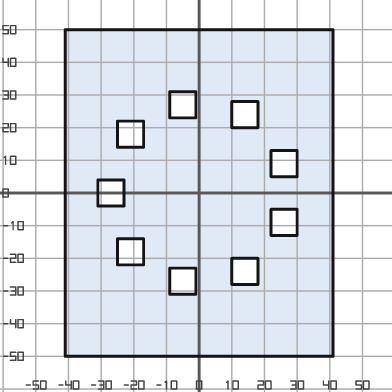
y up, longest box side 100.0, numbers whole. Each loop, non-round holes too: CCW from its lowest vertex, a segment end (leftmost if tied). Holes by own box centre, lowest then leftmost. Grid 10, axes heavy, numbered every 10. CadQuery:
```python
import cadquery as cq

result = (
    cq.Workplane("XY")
    .moveTo(-41.0, -50.0)
    .lineTo(41.0, -50.0)
    .lineTo(41.0, 50.0)
    .lineTo(-41.0, 50.0)
    .close()
    .moveTo(-9.0, -31.0)
    .lineTo(-1.0, -31.0)
    .lineTo(-1.0, -23.0)
    .lineTo(-9.0, -23.0)
    .close()
    .moveTo(10.0, -28.0)
    .lineTo(18.0, -28.0)
    .lineTo(18.0, -20.0)
    .lineTo(10.0, -20.0)
    .close()
    .moveTo(-25.0, -22.0)
    .lineTo(-17.0, -22.0)
    .lineTo(-17.0, -14.0)
    .lineTo(-25.0, -14.0)
    .close()
    .moveTo(22.0, -13.0)
    .lineTo(30.0, -13.0)
    .lineTo(30.0, -5.0)
    .lineTo(22.0, -5.0)
    .close()
    .moveTo(-31.0, -4.0)
    .lineTo(-23.0, -4.0)
    .lineTo(-23.0, 4.0)
    .lineTo(-31.0, 4.0)
    .close()
    .moveTo(22.0, 5.0)
    .lineTo(30.0, 5.0)
    .lineTo(30.0, 13.0)
    .lineTo(22.0, 13.0)
    .close()
    .moveTo(-25.0, 14.0)
    .lineTo(-17.0, 14.0)
    .lineTo(-17.0, 22.0)
    .lineTo(-25.0, 22.0)
    .close()
    .moveTo(10.0, 20.0)
    .lineTo(18.0, 20.0)
    .lineTo(18.0, 28.0)
    .lineTo(10.0, 28.0)
    .close()
    .moveTo(-9.0, 23.0)
    .lineTo(-1.0, 23.0)
    .lineTo(-1.0, 31.0)
    .lineTo(-9.0, 31.0)
    .close()
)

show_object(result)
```